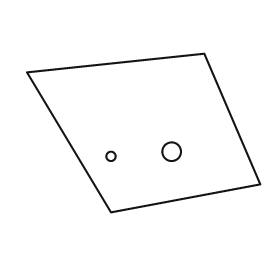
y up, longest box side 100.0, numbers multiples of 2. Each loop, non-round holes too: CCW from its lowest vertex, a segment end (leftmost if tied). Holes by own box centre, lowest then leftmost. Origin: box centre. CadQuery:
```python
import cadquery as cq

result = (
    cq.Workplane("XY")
    .moveTo(-14.0, -34.0)
    .lineTo(50.0, -22.0)
    .lineTo(26.0, 34.0)
    .lineTo(-50.0, 26.0)
    .close()
    .moveTo(-14.0, -10.0)
    .circle(2.0)
    .moveTo(12.0, -8.0)
    .circle(4.0)
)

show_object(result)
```